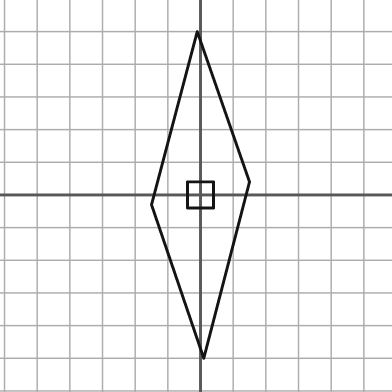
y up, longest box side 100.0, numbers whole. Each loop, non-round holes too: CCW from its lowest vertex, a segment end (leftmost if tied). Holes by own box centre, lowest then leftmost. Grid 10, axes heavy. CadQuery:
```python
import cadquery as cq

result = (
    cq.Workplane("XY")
    .moveTo(1.0, -50.0)
    .lineTo(15.0, 4.0)
    .lineTo(-1.0, 50.0)
    .lineTo(-15.0, -3.0)
    .close()
    .moveTo(-4.0, -4.0)
    .lineTo(4.0, -4.0)
    .lineTo(4.0, 4.0)
    .lineTo(-4.0, 4.0)
    .close()
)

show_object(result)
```